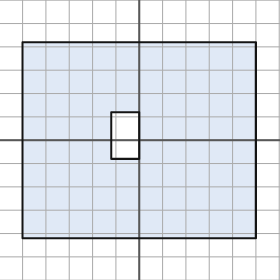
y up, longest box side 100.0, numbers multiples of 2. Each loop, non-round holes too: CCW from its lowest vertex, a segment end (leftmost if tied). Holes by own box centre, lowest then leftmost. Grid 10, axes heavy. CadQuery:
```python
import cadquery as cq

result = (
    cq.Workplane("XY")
    .moveTo(-50.0, -42.0)
    .lineTo(50.0, -42.0)
    .lineTo(50.0, 42.0)
    .lineTo(-50.0, 42.0)
    .close()
    .moveTo(-12.0, -8.0)
    .lineTo(0.0, -8.0)
    .lineTo(0.0, 12.0)
    .lineTo(-12.0, 12.0)
    .close()
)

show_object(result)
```